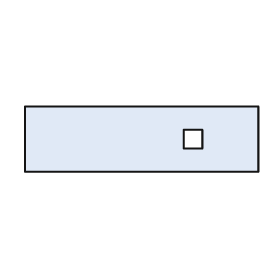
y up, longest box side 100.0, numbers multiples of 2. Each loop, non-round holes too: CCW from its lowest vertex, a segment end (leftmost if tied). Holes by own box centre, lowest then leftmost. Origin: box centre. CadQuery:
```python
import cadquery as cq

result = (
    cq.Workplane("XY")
    .moveTo(-50.0, -14.0)
    .lineTo(50.0, -14.0)
    .lineTo(50.0, 14.0)
    .lineTo(-50.0, 14.0)
    .close()
    .moveTo(18.0, -4.0)
    .lineTo(26.0, -4.0)
    .lineTo(26.0, 4.0)
    .lineTo(18.0, 4.0)
    .close()
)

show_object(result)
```